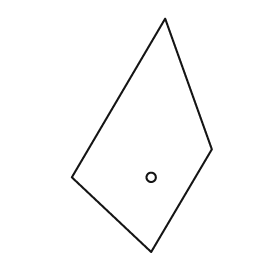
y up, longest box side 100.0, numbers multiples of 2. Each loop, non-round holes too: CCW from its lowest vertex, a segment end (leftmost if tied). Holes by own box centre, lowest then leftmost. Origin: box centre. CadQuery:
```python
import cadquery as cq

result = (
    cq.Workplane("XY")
    .moveTo(4.0, -50.0)
    .lineTo(30.0, -6.0)
    .lineTo(10.0, 50.0)
    .lineTo(-30.0, -18.0)
    .close()
    .moveTo(4.0, -18.0)
    .circle(2.0)
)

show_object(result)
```